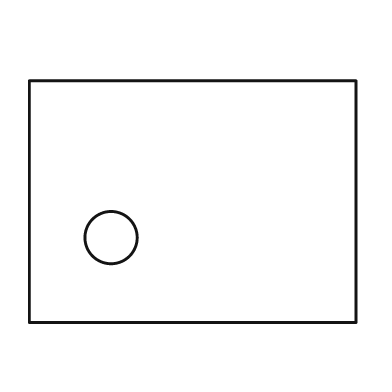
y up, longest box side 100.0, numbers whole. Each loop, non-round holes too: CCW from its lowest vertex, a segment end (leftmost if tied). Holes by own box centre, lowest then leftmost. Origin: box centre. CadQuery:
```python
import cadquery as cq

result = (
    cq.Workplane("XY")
    .moveTo(-50.0, -37.0)
    .lineTo(50.0, -37.0)
    .lineTo(50.0, 37.0)
    .lineTo(-50.0, 37.0)
    .close()
    .moveTo(-25.0, -11.0)
    .circle(8.0)
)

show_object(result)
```